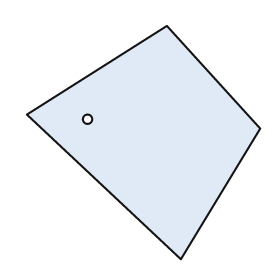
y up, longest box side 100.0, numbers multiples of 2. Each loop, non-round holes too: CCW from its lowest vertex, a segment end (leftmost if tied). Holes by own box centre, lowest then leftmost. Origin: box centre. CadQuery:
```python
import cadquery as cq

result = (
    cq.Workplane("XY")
    .moveTo(16.0, -50.0)
    .lineTo(50.0, 6.0)
    .lineTo(10.0, 50.0)
    .lineTo(-50.0, 12.0)
    .close()
    .moveTo(-24.0, 10.0)
    .circle(2.0)
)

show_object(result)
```